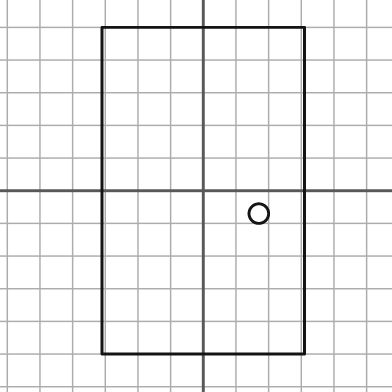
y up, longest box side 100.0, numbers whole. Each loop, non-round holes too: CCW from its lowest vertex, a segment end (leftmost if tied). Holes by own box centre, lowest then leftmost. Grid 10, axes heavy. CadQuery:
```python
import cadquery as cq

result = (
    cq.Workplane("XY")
    .moveTo(-31.0, -50.0)
    .lineTo(31.0, -50.0)
    .lineTo(31.0, 50.0)
    .lineTo(-31.0, 50.0)
    .close()
    .moveTo(17.0, -7.0)
    .circle(3.0)
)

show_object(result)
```